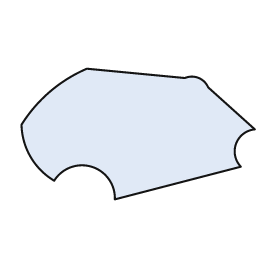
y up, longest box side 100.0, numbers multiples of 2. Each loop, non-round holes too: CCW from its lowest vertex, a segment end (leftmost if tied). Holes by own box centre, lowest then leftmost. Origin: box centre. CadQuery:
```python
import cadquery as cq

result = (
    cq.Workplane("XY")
    .moveTo(-10.0, -28.0)
    .lineTo(44.0, -14.0)
    .threePointArc((42.0, -4.0), (50.0, 2.0))
    .lineTo(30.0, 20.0)
    .threePointArc((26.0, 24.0), (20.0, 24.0))
    .lineTo(-22.0, 28.0)
    .threePointArc((-38.0, 18.0), (-50.0, 4.0))
    .threePointArc((-46.0, -10.0), (-36.0, -20.0))
    .threePointArc((-20.0, -14.0), (-10.0, -28.0))
    .close()
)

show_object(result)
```